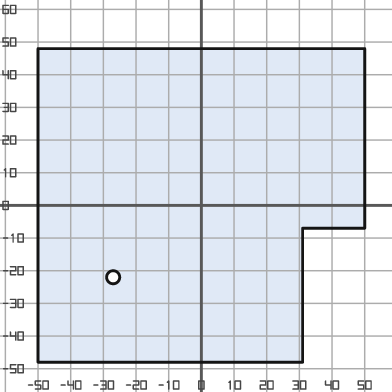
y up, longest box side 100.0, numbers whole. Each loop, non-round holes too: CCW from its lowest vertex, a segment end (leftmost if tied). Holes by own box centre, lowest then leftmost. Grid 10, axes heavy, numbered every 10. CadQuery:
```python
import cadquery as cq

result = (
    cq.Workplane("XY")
    .moveTo(-50.0, -48.0)
    .lineTo(31.0, -48.0)
    .lineTo(31.0, -7.0)
    .lineTo(50.0, -7.0)
    .lineTo(50.0, 48.0)
    .lineTo(-50.0, 48.0)
    .close()
    .moveTo(-27.0, -22.0)
    .circle(2.0)
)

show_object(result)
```